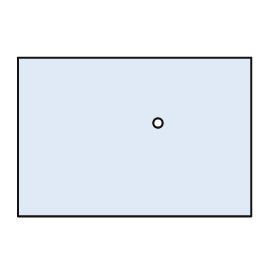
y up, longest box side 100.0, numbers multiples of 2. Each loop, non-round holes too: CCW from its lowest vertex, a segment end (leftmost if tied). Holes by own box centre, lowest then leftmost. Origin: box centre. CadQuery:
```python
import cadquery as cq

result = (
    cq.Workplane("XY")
    .moveTo(-50.0, -34.0)
    .lineTo(50.0, -34.0)
    .lineTo(50.0, 34.0)
    .lineTo(-50.0, 34.0)
    .close()
    .moveTo(10.0, 6.0)
    .circle(2.0)
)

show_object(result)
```